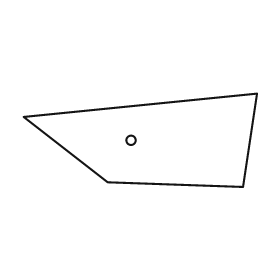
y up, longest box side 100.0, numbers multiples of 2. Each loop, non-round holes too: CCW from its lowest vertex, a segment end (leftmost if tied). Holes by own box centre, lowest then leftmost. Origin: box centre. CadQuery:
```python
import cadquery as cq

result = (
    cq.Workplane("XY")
    .moveTo(44.0, -20.0)
    .lineTo(50.0, 20.0)
    .lineTo(-50.0, 10.0)
    .lineTo(-14.0, -18.0)
    .close()
    .moveTo(-4.0, 0.0)
    .circle(2.0)
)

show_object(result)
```